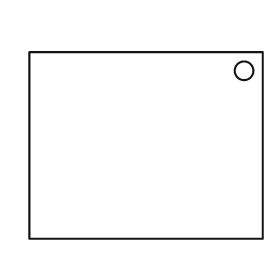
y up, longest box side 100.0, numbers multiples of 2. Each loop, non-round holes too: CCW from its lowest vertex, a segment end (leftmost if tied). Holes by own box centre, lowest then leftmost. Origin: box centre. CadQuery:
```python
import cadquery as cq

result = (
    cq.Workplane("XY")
    .moveTo(-50.0, -40.0)
    .lineTo(50.0, -40.0)
    .lineTo(50.0, 40.0)
    .lineTo(-50.0, 40.0)
    .close()
    .moveTo(42.0, 32.0)
    .circle(4.0)
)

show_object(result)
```